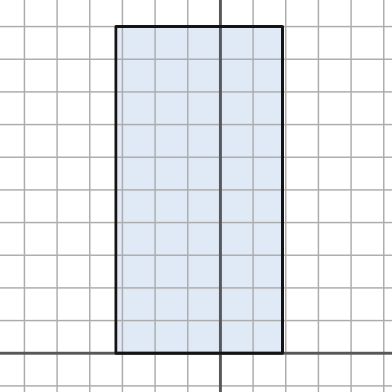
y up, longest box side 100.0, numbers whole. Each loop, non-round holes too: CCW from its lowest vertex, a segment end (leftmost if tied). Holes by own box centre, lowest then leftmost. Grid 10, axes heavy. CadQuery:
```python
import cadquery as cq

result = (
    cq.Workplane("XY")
    .moveTo(-32.0, 0.0)
    .lineTo(19.0, 0.0)
    .lineTo(19.0, 100.0)
    .lineTo(-32.0, 100.0)
    .close()
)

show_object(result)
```